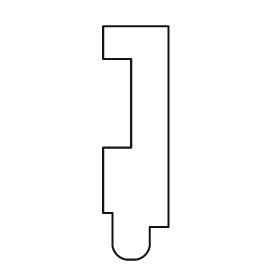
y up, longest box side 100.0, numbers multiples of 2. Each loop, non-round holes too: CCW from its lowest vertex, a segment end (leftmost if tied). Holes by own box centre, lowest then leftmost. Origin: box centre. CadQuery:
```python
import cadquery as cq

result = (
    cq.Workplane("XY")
    .moveTo(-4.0, -50.0)
    .lineTo(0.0, -50.0)
    .threePointArc((4.0, -48.0), (6.0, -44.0))
    .lineTo(6.0, -36.0)
    .lineTo(14.0, -36.0)
    .lineTo(14.0, 50.0)
    .lineTo(-14.0, 50.0)
    .lineTo(-14.0, 36.0)
    .lineTo(-2.0, 36.0)
    .lineTo(-2.0, -2.0)
    .lineTo(-14.0, -2.0)
    .lineTo(-14.0, -30.0)
    .lineTo(-10.0, -30.0)
    .lineTo(-10.0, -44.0)
    .threePointArc((-8.0, -48.0), (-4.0, -50.0))
    .close()
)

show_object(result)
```